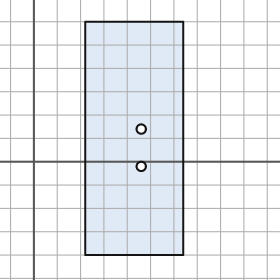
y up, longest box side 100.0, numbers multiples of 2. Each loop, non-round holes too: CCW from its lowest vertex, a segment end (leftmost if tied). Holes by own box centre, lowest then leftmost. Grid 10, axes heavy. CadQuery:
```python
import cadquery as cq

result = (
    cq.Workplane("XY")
    .moveTo(22.0, -40.0)
    .lineTo(64.0, -40.0)
    .lineTo(64.0, 60.0)
    .lineTo(22.0, 60.0)
    .close()
    .moveTo(46.0, -2.0)
    .circle(2.0)
    .moveTo(46.0, 14.0)
    .circle(2.0)
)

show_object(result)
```